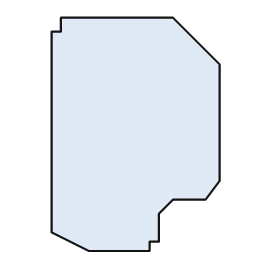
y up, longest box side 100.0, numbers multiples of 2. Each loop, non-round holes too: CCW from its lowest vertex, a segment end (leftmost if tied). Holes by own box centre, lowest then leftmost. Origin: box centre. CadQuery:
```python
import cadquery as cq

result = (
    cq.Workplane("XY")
    .moveTo(-20.0, -50.0)
    .lineTo(6.0, -50.0)
    .lineTo(6.0, -46.0)
    .lineTo(10.0, -46.0)
    .lineTo(10.0, -34.0)
    .lineTo(16.0, -28.0)
    .lineTo(30.0, -28.0)
    .lineTo(36.0, -20.0)
    .lineTo(36.0, 30.0)
    .lineTo(16.0, 50.0)
    .lineTo(-32.0, 50.0)
    .lineTo(-32.0, 44.0)
    .lineTo(-36.0, 44.0)
    .lineTo(-36.0, -42.0)
    .close()
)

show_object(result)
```